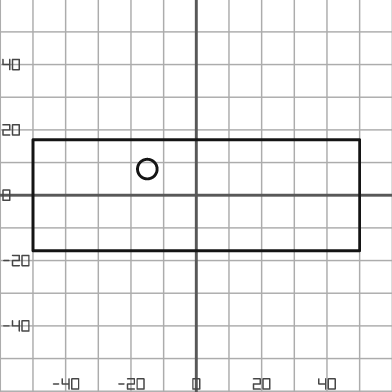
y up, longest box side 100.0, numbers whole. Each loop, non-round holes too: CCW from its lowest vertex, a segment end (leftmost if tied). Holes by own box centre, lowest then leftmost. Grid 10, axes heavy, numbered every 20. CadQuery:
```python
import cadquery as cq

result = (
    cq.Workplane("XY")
    .moveTo(-50.0, -17.0)
    .lineTo(50.0, -17.0)
    .lineTo(50.0, 17.0)
    .lineTo(-50.0, 17.0)
    .close()
    .moveTo(-15.0, 8.0)
    .circle(3.0)
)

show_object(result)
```